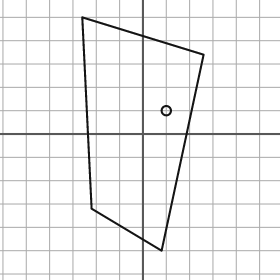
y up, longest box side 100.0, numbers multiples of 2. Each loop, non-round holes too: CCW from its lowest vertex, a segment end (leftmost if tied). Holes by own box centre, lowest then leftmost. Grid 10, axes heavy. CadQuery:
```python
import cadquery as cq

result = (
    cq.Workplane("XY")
    .moveTo(8.0, -50.0)
    .lineTo(26.0, 34.0)
    .lineTo(-26.0, 50.0)
    .lineTo(-22.0, -32.0)
    .close()
    .moveTo(10.0, 10.0)
    .circle(2.0)
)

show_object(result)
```